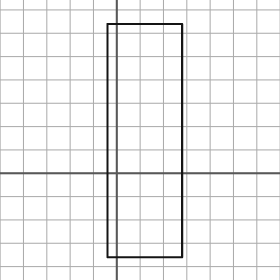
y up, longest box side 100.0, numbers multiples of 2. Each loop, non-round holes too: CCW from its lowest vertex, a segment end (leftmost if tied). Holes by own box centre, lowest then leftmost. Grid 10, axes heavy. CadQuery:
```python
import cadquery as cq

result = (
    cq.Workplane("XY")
    .moveTo(-4.0, -36.0)
    .lineTo(28.0, -36.0)
    .lineTo(28.0, 64.0)
    .lineTo(-4.0, 64.0)
    .close()
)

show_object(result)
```